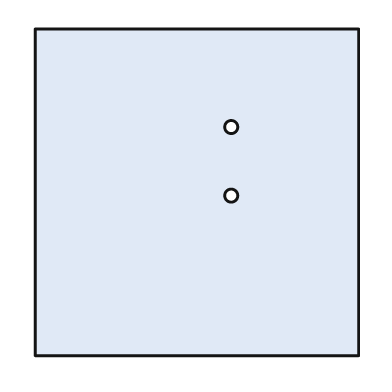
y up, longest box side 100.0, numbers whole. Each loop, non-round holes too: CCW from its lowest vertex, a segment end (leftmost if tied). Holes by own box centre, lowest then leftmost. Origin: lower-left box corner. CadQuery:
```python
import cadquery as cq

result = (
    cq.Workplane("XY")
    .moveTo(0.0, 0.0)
    .lineTo(99.0, 0.0)
    .lineTo(99.0, 100.0)
    .lineTo(0.0, 100.0)
    .close()
    .moveTo(60.0, 49.0)
    .circle(2.0)
    .moveTo(60.0, 70.0)
    .circle(2.0)
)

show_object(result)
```